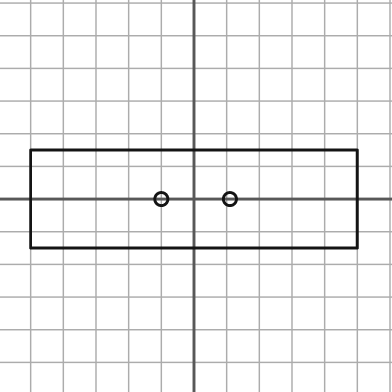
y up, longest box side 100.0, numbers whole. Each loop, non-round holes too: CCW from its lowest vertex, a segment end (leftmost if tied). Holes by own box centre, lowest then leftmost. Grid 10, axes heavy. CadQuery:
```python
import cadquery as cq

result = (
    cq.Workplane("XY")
    .moveTo(-50.0, -15.0)
    .lineTo(50.0, -15.0)
    .lineTo(50.0, 15.0)
    .lineTo(-50.0, 15.0)
    .close()
    .moveTo(-10.0, 0.0)
    .circle(2.0)
    .moveTo(11.0, 0.0)
    .circle(2.0)
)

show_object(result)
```